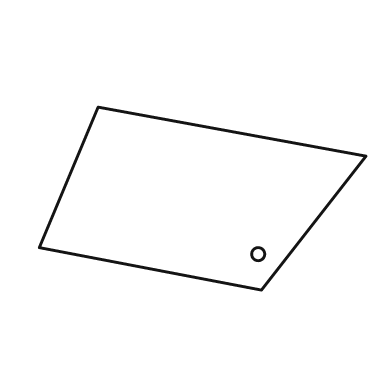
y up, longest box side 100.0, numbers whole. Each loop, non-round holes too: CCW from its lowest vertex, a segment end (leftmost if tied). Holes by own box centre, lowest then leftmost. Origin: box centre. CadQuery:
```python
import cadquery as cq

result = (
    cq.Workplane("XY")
    .moveTo(18.0, -28.0)
    .lineTo(50.0, 13.0)
    .lineTo(-32.0, 28.0)
    .lineTo(-50.0, -15.0)
    .close()
    .moveTo(17.0, -17.0)
    .circle(2.0)
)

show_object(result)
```